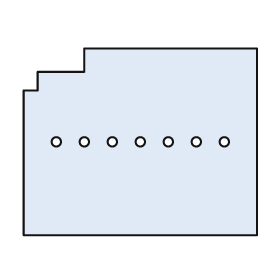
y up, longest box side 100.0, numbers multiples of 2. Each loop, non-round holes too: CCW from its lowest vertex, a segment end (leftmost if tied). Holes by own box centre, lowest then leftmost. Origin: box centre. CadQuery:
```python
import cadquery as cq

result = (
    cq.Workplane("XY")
    .moveTo(-50.0, -40.0)
    .lineTo(50.0, -40.0)
    .lineTo(50.0, 40.0)
    .lineTo(-24.0, 40.0)
    .lineTo(-24.0, 30.0)
    .lineTo(-44.0, 30.0)
    .lineTo(-44.0, 22.0)
    .lineTo(-50.0, 22.0)
    .close()
    .moveTo(-36.0, 0.0)
    .circle(2.0)
    .moveTo(-24.0, 0.0)
    .circle(2.0)
    .moveTo(-12.0, 0.0)
    .circle(2.0)
    .moveTo(0.0, 0.0)
    .circle(2.0)
    .moveTo(12.0, 0.0)
    .circle(2.0)
    .moveTo(24.0, 0.0)
    .circle(2.0)
    .moveTo(36.0, 0.0)
    .circle(2.0)
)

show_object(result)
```